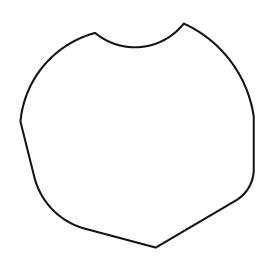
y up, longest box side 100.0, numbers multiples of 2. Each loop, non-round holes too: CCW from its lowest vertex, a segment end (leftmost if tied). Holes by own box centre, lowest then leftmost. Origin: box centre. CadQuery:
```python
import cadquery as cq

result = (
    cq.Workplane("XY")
    .moveTo(8.0, -48.0)
    .lineTo(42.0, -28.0)
    .threePointArc((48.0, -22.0), (50.0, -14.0))
    .lineTo(50.0, 8.0)
    .threePointArc((40.0, 32.0), (20.0, 48.0))
    .threePointArc((2.0, 38.0), (-18.0, 44.0))
    .threePointArc((-40.0, 30.0), (-50.0, 6.0))
    .lineTo(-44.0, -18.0)
    .threePointArc((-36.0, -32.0), (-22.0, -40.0))
    .close()
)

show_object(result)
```